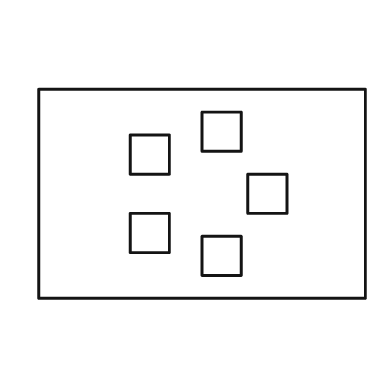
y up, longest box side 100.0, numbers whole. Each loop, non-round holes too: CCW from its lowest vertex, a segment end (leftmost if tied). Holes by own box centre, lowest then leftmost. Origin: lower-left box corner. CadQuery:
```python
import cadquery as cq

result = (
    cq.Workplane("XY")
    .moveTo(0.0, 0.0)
    .lineTo(100.0, 0.0)
    .lineTo(100.0, 64.0)
    .lineTo(0.0, 64.0)
    .close()
    .moveTo(50.0, 7.0)
    .lineTo(62.0, 7.0)
    .lineTo(62.0, 19.0)
    .lineTo(50.0, 19.0)
    .close()
    .moveTo(28.0, 14.0)
    .lineTo(40.0, 14.0)
    .lineTo(40.0, 26.0)
    .lineTo(28.0, 26.0)
    .close()
    .moveTo(64.0, 26.0)
    .lineTo(76.0, 26.0)
    .lineTo(76.0, 38.0)
    .lineTo(64.0, 38.0)
    .close()
    .moveTo(28.0, 38.0)
    .lineTo(40.0, 38.0)
    .lineTo(40.0, 50.0)
    .lineTo(28.0, 50.0)
    .close()
    .moveTo(50.0, 45.0)
    .lineTo(62.0, 45.0)
    .lineTo(62.0, 57.0)
    .lineTo(50.0, 57.0)
    .close()
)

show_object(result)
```